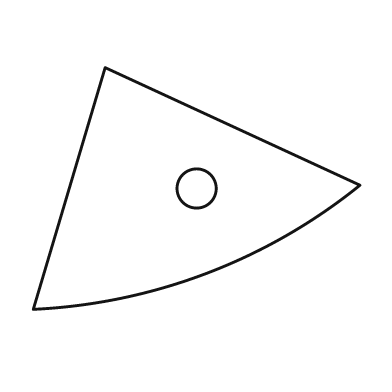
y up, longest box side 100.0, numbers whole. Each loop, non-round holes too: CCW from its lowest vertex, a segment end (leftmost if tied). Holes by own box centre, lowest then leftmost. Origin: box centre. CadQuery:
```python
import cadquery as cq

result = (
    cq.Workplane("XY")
    .moveTo(-50.0, -37.0)
    .threePointArc((3.0, -26.0), (50.0, 1.0))
    .lineTo(-28.0, 37.0)
    .close()
    .moveTo(0.0, 0.0)
    .circle(6.0)
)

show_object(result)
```